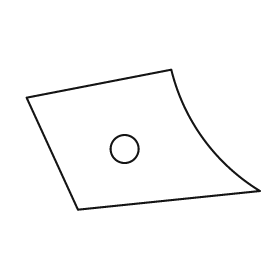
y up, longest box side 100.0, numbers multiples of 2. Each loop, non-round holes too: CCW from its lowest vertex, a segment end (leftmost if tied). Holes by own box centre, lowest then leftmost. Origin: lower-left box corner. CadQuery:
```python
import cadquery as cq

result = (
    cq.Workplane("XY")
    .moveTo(22.0, 0.0)
    .lineTo(100.0, 8.0)
    .threePointArc((76.0, 30.0), (62.0, 60.0))
    .lineTo(0.0, 48.0)
    .close()
    .moveTo(42.0, 26.0)
    .circle(6.0)
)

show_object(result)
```